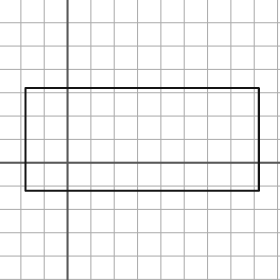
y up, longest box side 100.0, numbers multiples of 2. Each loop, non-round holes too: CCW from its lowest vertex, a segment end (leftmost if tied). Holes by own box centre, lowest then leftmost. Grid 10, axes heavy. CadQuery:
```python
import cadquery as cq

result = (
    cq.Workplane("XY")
    .moveTo(-18.0, -12.0)
    .lineTo(82.0, -12.0)
    .lineTo(82.0, 32.0)
    .lineTo(-18.0, 32.0)
    .close()
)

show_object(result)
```